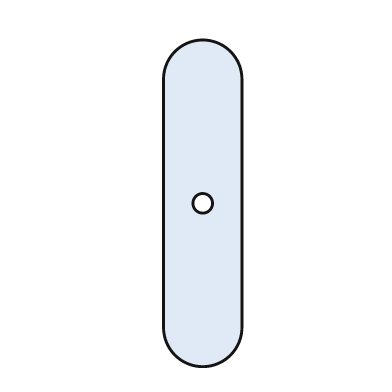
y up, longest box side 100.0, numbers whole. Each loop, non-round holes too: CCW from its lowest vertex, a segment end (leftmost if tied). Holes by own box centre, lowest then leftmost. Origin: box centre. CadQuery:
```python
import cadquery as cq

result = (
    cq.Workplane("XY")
    .moveTo(-12.0, -38.0)
    .threePointArc((0.0, -50.0), (12.0, -38.0))
    .lineTo(12.0, 38.0)
    .threePointArc((0.0, 50.0), (-12.0, 38.0))
    .close()
    .moveTo(0.0, 0.0)
    .circle(3.0)
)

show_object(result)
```